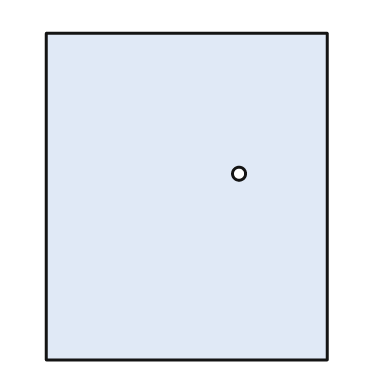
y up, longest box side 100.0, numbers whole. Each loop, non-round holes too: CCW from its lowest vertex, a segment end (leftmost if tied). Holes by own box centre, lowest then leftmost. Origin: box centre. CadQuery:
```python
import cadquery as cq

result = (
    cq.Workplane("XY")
    .moveTo(-43.0, -50.0)
    .lineTo(43.0, -50.0)
    .lineTo(43.0, 50.0)
    .lineTo(-43.0, 50.0)
    .close()
    .moveTo(16.0, 7.0)
    .circle(2.0)
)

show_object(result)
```